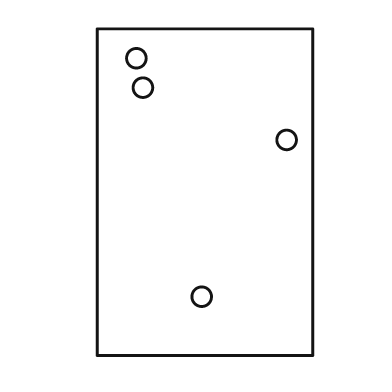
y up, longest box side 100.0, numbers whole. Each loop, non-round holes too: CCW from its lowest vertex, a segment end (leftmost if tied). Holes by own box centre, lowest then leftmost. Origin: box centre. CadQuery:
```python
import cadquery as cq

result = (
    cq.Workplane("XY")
    .moveTo(-33.0, -50.0)
    .lineTo(33.0, -50.0)
    .lineTo(33.0, 50.0)
    .lineTo(-33.0, 50.0)
    .close()
    .moveTo(-1.0, -32.0)
    .circle(3.0)
    .moveTo(25.0, 16.0)
    .circle(3.0)
    .moveTo(-19.0, 32.0)
    .circle(3.0)
    .moveTo(-21.0, 41.0)
    .circle(3.0)
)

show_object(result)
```